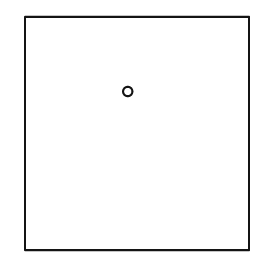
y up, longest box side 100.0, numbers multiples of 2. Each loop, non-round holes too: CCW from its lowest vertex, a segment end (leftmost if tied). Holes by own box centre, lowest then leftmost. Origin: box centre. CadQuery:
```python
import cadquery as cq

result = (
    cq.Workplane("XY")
    .moveTo(-48.0, -50.0)
    .lineTo(48.0, -50.0)
    .lineTo(48.0, 50.0)
    .lineTo(-48.0, 50.0)
    .close()
    .moveTo(-4.0, 18.0)
    .circle(2.0)
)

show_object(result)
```